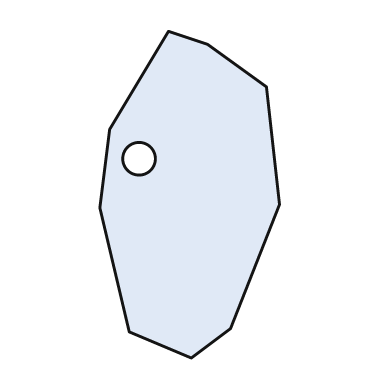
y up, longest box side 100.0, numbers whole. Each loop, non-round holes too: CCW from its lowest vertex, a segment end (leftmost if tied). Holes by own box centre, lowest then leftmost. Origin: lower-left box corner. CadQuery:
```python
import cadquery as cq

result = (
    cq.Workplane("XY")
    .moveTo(28.0, 0.0)
    .lineTo(40.0, 9.0)
    .lineTo(55.0, 47.0)
    .lineTo(51.0, 83.0)
    .lineTo(33.0, 96.0)
    .lineTo(21.0, 100.0)
    .lineTo(3.0, 70.0)
    .lineTo(0.0, 46.0)
    .lineTo(9.0, 8.0)
    .close()
    .moveTo(12.0, 61.0)
    .circle(5.0)
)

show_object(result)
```